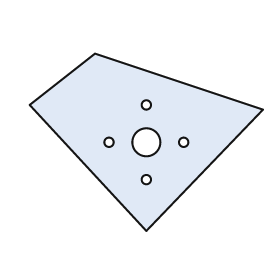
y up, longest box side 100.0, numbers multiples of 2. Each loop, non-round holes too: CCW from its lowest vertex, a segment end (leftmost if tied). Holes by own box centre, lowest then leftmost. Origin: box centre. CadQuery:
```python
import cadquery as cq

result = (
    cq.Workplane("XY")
    .moveTo(0.0, -38.0)
    .lineTo(50.0, 14.0)
    .lineTo(-22.0, 38.0)
    .lineTo(-50.0, 16.0)
    .close()
    .moveTo(0.0, -16.0)
    .circle(2.0)
    .moveTo(-16.0, 0.0)
    .circle(2.0)
    .moveTo(0.0, 0.0)
    .circle(6.0)
    .moveTo(16.0, 0.0)
    .circle(2.0)
    .moveTo(0.0, 16.0)
    .circle(2.0)
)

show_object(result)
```